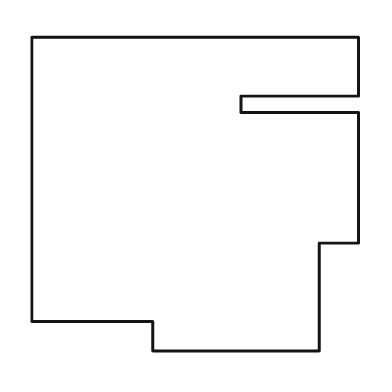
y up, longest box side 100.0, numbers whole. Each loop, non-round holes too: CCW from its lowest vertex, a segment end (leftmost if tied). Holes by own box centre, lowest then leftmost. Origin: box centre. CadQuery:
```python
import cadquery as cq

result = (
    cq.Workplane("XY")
    .moveTo(-13.0, -48.0)
    .lineTo(38.0, -48.0)
    .lineTo(38.0, -15.0)
    .lineTo(50.0, -15.0)
    .lineTo(50.0, 25.0)
    .lineTo(14.0, 25.0)
    .lineTo(14.0, 30.0)
    .lineTo(50.0, 30.0)
    .lineTo(50.0, 48.0)
    .lineTo(-50.0, 48.0)
    .lineTo(-50.0, -39.0)
    .lineTo(-13.0, -39.0)
    .close()
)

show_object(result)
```